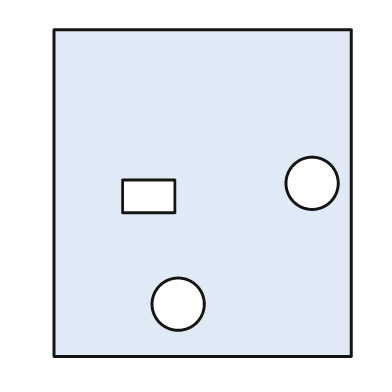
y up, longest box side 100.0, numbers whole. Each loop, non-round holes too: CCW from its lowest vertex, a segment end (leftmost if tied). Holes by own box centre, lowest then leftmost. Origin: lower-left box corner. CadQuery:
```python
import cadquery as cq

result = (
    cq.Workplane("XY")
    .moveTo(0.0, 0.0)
    .lineTo(91.0, 0.0)
    .lineTo(91.0, 100.0)
    .lineTo(0.0, 100.0)
    .close()
    .moveTo(38.0, 16.0)
    .circle(8.0)
    .moveTo(21.0, 44.0)
    .lineTo(37.0, 44.0)
    .lineTo(37.0, 54.0)
    .lineTo(21.0, 54.0)
    .close()
    .moveTo(79.0, 53.0)
    .circle(8.0)
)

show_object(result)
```